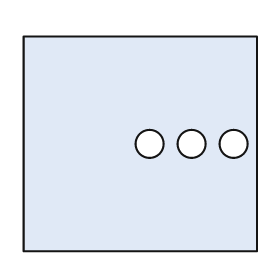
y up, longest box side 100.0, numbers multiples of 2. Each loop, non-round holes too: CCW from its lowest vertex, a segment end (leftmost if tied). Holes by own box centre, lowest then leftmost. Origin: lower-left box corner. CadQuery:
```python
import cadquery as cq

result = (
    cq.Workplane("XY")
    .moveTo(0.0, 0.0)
    .lineTo(100.0, 0.0)
    .lineTo(100.0, 92.0)
    .lineTo(0.0, 92.0)
    .close()
    .moveTo(54.0, 46.0)
    .circle(6.0)
    .moveTo(72.0, 46.0)
    .circle(6.0)
    .moveTo(90.0, 46.0)
    .circle(6.0)
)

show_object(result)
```